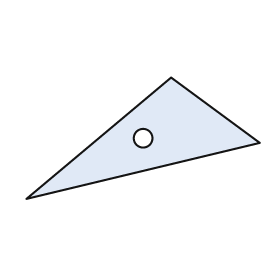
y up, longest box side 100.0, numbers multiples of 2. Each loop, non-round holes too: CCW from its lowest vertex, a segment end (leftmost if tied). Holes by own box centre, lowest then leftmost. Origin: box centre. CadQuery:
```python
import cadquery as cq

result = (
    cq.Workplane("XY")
    .moveTo(-50.0, -26.0)
    .lineTo(50.0, -2.0)
    .lineTo(12.0, 26.0)
    .close()
    .moveTo(0.0, 0.0)
    .circle(4.0)
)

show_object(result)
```